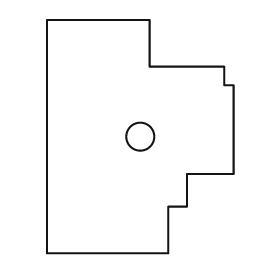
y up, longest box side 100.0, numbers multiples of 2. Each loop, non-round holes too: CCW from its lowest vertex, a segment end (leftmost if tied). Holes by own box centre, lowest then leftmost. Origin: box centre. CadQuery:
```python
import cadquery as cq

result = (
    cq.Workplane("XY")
    .moveTo(-40.0, -50.0)
    .lineTo(12.0, -50.0)
    .lineTo(12.0, -30.0)
    .lineTo(20.0, -30.0)
    .lineTo(20.0, -16.0)
    .lineTo(40.0, -16.0)
    .lineTo(40.0, 22.0)
    .lineTo(36.0, 22.0)
    .lineTo(36.0, 30.0)
    .lineTo(4.0, 30.0)
    .lineTo(4.0, 50.0)
    .lineTo(-40.0, 50.0)
    .close()
    .moveTo(0.0, 0.0)
    .circle(6.0)
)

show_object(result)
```